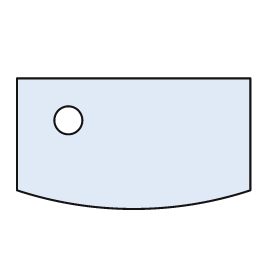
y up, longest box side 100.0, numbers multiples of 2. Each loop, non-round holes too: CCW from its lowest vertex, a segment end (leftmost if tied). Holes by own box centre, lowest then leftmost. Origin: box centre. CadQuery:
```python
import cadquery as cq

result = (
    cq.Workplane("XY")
    .moveTo(-50.0, -20.0)
    .threePointArc((0.0, -28.0), (50.0, -20.0))
    .lineTo(50.0, 28.0)
    .lineTo(-50.0, 28.0)
    .close()
    .moveTo(-28.0, 10.0)
    .circle(6.0)
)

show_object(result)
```